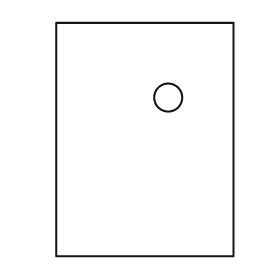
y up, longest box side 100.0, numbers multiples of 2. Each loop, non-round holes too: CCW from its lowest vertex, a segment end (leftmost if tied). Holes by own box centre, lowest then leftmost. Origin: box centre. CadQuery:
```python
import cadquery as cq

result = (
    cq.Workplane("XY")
    .moveTo(-38.0, -50.0)
    .lineTo(38.0, -50.0)
    .lineTo(38.0, 50.0)
    .lineTo(-38.0, 50.0)
    .close()
    .moveTo(10.0, 18.0)
    .circle(6.0)
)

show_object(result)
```